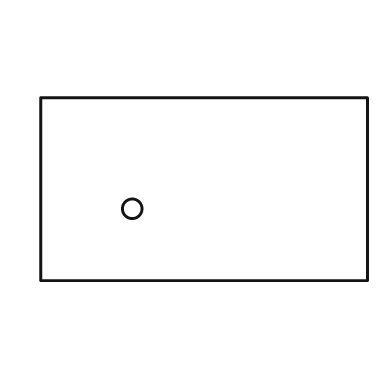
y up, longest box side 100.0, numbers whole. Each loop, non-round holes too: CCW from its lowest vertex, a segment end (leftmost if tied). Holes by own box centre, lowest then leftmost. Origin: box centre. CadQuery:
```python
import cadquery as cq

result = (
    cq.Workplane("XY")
    .moveTo(-50.0, -28.0)
    .lineTo(50.0, -28.0)
    .lineTo(50.0, 28.0)
    .lineTo(-50.0, 28.0)
    .close()
    .moveTo(-22.0, -6.0)
    .circle(3.0)
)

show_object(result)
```